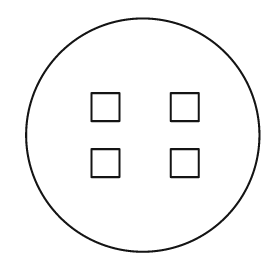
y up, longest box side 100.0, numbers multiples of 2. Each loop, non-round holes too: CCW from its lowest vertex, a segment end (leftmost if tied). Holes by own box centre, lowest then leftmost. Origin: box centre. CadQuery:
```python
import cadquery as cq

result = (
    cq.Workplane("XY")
    .moveTo(0.0, 0.0)
    .circle(50.0)
    .moveTo(-22.0, -18.0)
    .lineTo(-10.0, -18.0)
    .lineTo(-10.0, -6.0)
    .lineTo(-22.0, -6.0)
    .close()
    .moveTo(12.0, -18.0)
    .lineTo(24.0, -18.0)
    .lineTo(24.0, -6.0)
    .lineTo(12.0, -6.0)
    .close()
    .moveTo(-22.0, 6.0)
    .lineTo(-10.0, 6.0)
    .lineTo(-10.0, 18.0)
    .lineTo(-22.0, 18.0)
    .close()
    .moveTo(12.0, 6.0)
    .lineTo(24.0, 6.0)
    .lineTo(24.0, 18.0)
    .lineTo(12.0, 18.0)
    .close()
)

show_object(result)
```